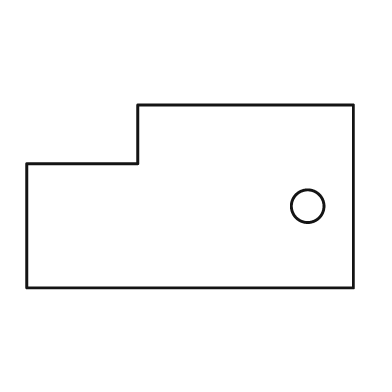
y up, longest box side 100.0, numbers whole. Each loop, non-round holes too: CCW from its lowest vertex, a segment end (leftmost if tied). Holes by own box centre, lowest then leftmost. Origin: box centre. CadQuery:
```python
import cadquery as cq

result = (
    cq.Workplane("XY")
    .moveTo(-50.0, -28.0)
    .lineTo(50.0, -28.0)
    .lineTo(50.0, 28.0)
    .lineTo(-16.0, 28.0)
    .lineTo(-16.0, 10.0)
    .lineTo(-50.0, 10.0)
    .close()
    .moveTo(36.0, -3.0)
    .circle(5.0)
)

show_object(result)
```